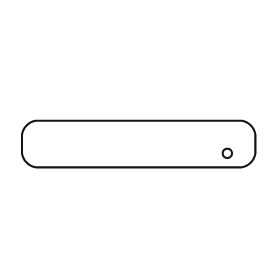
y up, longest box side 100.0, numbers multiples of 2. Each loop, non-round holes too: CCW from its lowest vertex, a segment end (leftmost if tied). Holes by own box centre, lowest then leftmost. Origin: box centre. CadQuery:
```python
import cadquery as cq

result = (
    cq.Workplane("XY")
    .moveTo(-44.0, -10.0)
    .lineTo(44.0, -10.0)
    .threePointArc((48.0, -8.0), (50.0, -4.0))
    .lineTo(50.0, 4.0)
    .threePointArc((48.0, 8.0), (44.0, 10.0))
    .lineTo(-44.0, 10.0)
    .threePointArc((-48.0, 8.0), (-50.0, 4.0))
    .lineTo(-50.0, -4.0)
    .threePointArc((-48.0, -8.0), (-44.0, -10.0))
    .close()
    .moveTo(38.0, -4.0)
    .circle(2.0)
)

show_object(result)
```